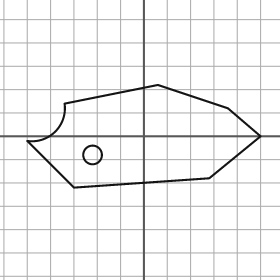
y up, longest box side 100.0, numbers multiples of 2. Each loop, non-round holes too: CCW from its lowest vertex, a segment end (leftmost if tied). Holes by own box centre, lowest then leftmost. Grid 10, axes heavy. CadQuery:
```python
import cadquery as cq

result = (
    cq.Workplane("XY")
    .moveTo(-30.0, -22.0)
    .lineTo(28.0, -18.0)
    .lineTo(50.0, 0.0)
    .lineTo(36.0, 12.0)
    .lineTo(6.0, 22.0)
    .lineTo(-34.0, 14.0)
    .threePointArc((-38.0, 2.0), (-50.0, -2.0))
    .close()
    .moveTo(-22.0, -8.0)
    .circle(4.0)
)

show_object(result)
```